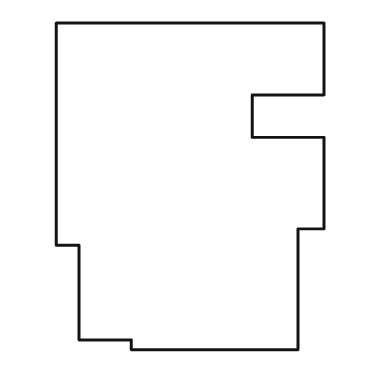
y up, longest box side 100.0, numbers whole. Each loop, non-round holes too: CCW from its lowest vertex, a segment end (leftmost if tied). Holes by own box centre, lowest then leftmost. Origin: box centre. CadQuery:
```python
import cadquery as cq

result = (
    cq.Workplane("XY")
    .moveTo(-18.0, -50.0)
    .lineTo(33.0, -50.0)
    .lineTo(33.0, -13.0)
    .lineTo(41.0, -13.0)
    .lineTo(41.0, 15.0)
    .lineTo(19.0, 15.0)
    .lineTo(19.0, 28.0)
    .lineTo(41.0, 28.0)
    .lineTo(41.0, 50.0)
    .lineTo(-41.0, 50.0)
    .lineTo(-41.0, -18.0)
    .lineTo(-34.0, -18.0)
    .lineTo(-34.0, -47.0)
    .lineTo(-18.0, -47.0)
    .close()
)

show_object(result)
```